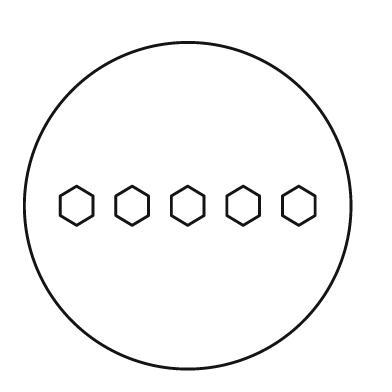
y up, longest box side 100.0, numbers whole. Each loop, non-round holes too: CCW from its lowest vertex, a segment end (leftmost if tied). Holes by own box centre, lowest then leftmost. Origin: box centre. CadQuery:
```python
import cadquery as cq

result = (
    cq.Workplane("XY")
    .moveTo(0.0, 0.0)
    .circle(50.0)
    .moveTo(-34.0, -6.0)
    .lineTo(-29.0, -3.0)
    .lineTo(-29.0, 3.0)
    .lineTo(-34.0, 6.0)
    .lineTo(-39.0, 3.0)
    .lineTo(-39.0, -3.0)
    .close()
    .moveTo(-17.0, -6.0)
    .lineTo(-12.0, -3.0)
    .lineTo(-12.0, 3.0)
    .lineTo(-17.0, 6.0)
    .lineTo(-22.0, 3.0)
    .lineTo(-22.0, -3.0)
    .close()
    .moveTo(0.0, -6.0)
    .lineTo(5.0, -3.0)
    .lineTo(5.0, 3.0)
    .lineTo(0.0, 6.0)
    .lineTo(-5.0, 3.0)
    .lineTo(-5.0, -3.0)
    .close()
    .moveTo(17.0, -6.0)
    .lineTo(22.0, -3.0)
    .lineTo(22.0, 3.0)
    .lineTo(17.0, 6.0)
    .lineTo(12.0, 3.0)
    .lineTo(12.0, -3.0)
    .close()
    .moveTo(34.0, -6.0)
    .lineTo(39.0, -3.0)
    .lineTo(39.0, 3.0)
    .lineTo(34.0, 6.0)
    .lineTo(29.0, 3.0)
    .lineTo(29.0, -3.0)
    .close()
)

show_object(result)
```